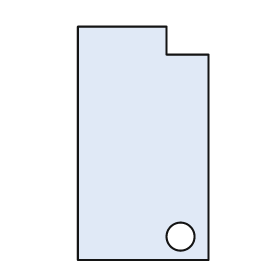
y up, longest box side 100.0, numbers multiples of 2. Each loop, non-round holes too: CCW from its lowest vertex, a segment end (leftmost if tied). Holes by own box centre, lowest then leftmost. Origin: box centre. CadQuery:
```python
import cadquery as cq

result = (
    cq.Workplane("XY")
    .moveTo(-28.0, -50.0)
    .lineTo(28.0, -50.0)
    .lineTo(28.0, 38.0)
    .lineTo(10.0, 38.0)
    .lineTo(10.0, 50.0)
    .lineTo(-28.0, 50.0)
    .close()
    .moveTo(16.0, -40.0)
    .circle(6.0)
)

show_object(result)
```